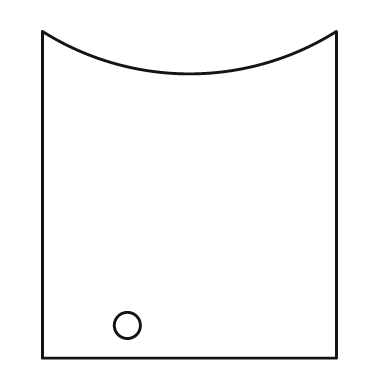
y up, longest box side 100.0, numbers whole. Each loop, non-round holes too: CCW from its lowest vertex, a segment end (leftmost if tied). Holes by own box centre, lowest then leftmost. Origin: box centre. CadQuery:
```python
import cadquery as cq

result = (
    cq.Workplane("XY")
    .moveTo(-45.0, -50.0)
    .lineTo(45.0, -50.0)
    .lineTo(45.0, 50.0)
    .threePointArc((0.0, 37.0), (-45.0, 50.0))
    .close()
    .moveTo(-19.0, -40.0)
    .circle(4.0)
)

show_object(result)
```